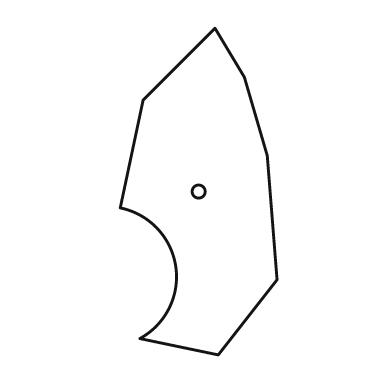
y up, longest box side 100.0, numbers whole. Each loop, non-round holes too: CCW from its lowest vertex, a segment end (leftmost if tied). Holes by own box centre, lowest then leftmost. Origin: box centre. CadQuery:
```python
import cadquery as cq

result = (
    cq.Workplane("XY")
    .moveTo(6.0, -50.0)
    .lineTo(24.0, -27.0)
    .lineTo(21.0, 11.0)
    .lineTo(14.0, 35.0)
    .lineTo(5.0, 50.0)
    .lineTo(-17.0, 28.0)
    .lineTo(-24.0, -5.0)
    .threePointArc((-7.0, -23.0), (-18.0, -45.0))
    .close()
    .moveTo(0.0, 0.0)
    .circle(2.0)
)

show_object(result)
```